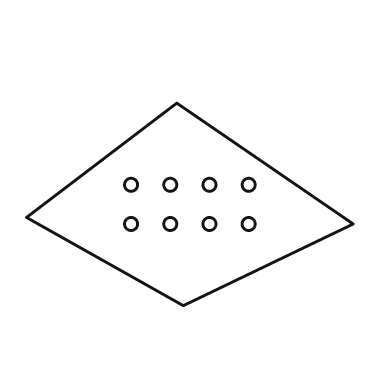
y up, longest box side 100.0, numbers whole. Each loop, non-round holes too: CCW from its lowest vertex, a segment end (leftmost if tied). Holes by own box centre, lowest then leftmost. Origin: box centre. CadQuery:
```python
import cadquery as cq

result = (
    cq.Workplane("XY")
    .moveTo(-2.0, -31.0)
    .lineTo(50.0, -6.0)
    .lineTo(-4.0, 31.0)
    .lineTo(-50.0, -4.0)
    .close()
    .moveTo(-18.0, -6.0)
    .circle(2.0)
    .moveTo(-6.0, -6.0)
    .circle(2.0)
    .moveTo(6.0, -6.0)
    .circle(2.0)
    .moveTo(18.0, -6.0)
    .circle(2.0)
    .moveTo(-18.0, 6.0)
    .circle(2.0)
    .moveTo(-6.0, 6.0)
    .circle(2.0)
    .moveTo(6.0, 6.0)
    .circle(2.0)
    .moveTo(18.0, 6.0)
    .circle(2.0)
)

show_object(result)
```